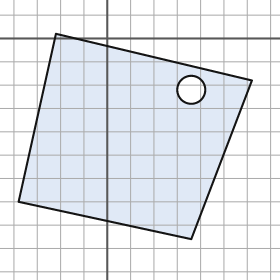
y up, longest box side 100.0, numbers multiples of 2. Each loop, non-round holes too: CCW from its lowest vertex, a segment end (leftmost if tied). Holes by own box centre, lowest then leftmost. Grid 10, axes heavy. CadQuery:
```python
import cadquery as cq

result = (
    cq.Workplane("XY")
    .moveTo(36.0, -86.0)
    .lineTo(62.0, -18.0)
    .lineTo(-22.0, 2.0)
    .lineTo(-38.0, -70.0)
    .close()
    .moveTo(36.0, -22.0)
    .circle(6.0)
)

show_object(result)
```